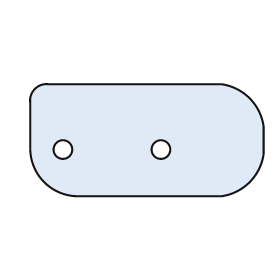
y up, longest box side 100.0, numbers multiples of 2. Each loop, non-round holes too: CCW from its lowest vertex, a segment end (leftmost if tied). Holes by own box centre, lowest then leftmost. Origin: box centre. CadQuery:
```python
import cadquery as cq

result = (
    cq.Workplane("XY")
    .moveTo(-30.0, -24.0)
    .lineTo(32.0, -24.0)
    .threePointArc((44.0, -18.0), (50.0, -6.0))
    .lineTo(50.0, 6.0)
    .threePointArc((44.0, 18.0), (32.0, 24.0))
    .lineTo(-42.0, 24.0)
    .threePointArc((-48.0, 22.0), (-50.0, 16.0))
    .lineTo(-50.0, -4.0)
    .threePointArc((-44.0, -18.0), (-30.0, -24.0))
    .close()
    .moveTo(-36.0, -4.0)
    .circle(4.0)
    .moveTo(6.0, -4.0)
    .circle(4.0)
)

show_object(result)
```